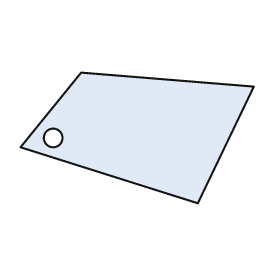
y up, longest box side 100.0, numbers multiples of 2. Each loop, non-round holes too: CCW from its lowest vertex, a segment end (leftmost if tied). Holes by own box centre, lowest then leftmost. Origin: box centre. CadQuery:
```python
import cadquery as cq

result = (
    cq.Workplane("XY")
    .moveTo(26.0, -28.0)
    .lineTo(50.0, 22.0)
    .lineTo(-24.0, 28.0)
    .lineTo(-50.0, -4.0)
    .close()
    .moveTo(-36.0, 0.0)
    .circle(4.0)
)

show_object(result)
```